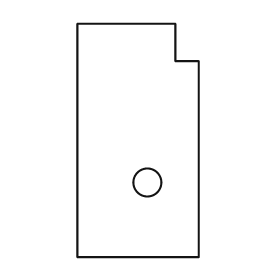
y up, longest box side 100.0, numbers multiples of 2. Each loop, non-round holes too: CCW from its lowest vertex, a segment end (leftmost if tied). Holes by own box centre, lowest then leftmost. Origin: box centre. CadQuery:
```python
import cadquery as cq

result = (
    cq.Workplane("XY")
    .moveTo(-26.0, -50.0)
    .lineTo(26.0, -50.0)
    .lineTo(26.0, 34.0)
    .lineTo(16.0, 34.0)
    .lineTo(16.0, 50.0)
    .lineTo(-26.0, 50.0)
    .close()
    .moveTo(4.0, -18.0)
    .circle(6.0)
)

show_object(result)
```